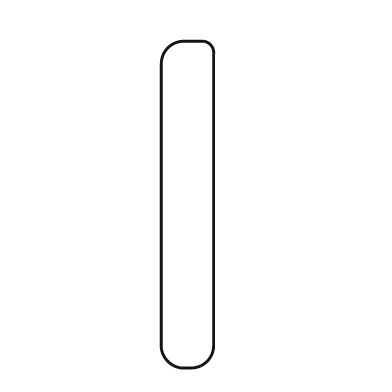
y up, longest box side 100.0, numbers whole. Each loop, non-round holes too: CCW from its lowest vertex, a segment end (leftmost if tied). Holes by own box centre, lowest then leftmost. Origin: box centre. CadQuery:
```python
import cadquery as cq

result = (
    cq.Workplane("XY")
    .moveTo(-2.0, -50.0)
    .lineTo(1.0, -50.0)
    .threePointArc((6.0, -48.0), (8.0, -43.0))
    .lineTo(8.0, 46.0)
    .threePointArc((7.0, 49.0), (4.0, 50.0))
    .lineTo(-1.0, 50.0)
    .threePointArc((-6.0, 48.0), (-8.0, 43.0))
    .lineTo(-8.0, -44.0)
    .threePointArc((-6.0, -48.0), (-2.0, -50.0))
    .close()
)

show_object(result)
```